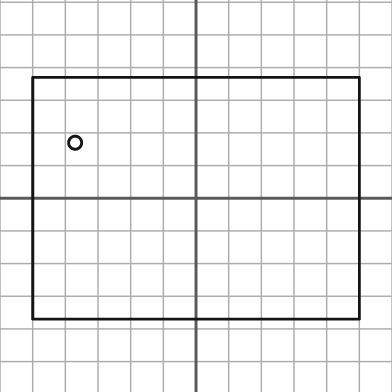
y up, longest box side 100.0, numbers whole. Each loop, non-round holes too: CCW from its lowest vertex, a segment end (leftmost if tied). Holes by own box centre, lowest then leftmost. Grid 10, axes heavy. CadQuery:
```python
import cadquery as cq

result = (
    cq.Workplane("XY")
    .moveTo(-50.0, -37.0)
    .lineTo(50.0, -37.0)
    .lineTo(50.0, 37.0)
    .lineTo(-50.0, 37.0)
    .close()
    .moveTo(-37.0, 17.0)
    .circle(2.0)
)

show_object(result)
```